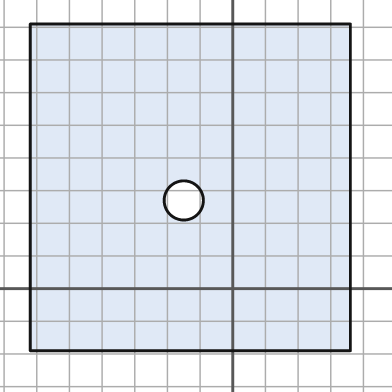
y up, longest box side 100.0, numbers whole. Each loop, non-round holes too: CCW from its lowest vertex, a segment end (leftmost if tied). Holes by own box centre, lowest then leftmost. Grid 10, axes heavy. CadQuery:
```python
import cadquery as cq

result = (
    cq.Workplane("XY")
    .moveTo(-62.0, -19.0)
    .lineTo(36.0, -19.0)
    .lineTo(36.0, 81.0)
    .lineTo(-62.0, 81.0)
    .close()
    .moveTo(-15.0, 27.0)
    .circle(6.0)
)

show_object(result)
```